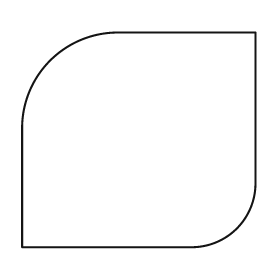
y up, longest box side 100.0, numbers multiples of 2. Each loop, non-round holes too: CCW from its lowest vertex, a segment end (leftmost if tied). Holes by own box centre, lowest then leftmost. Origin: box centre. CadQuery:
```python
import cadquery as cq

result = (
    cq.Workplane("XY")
    .moveTo(-50.0, -46.0)
    .lineTo(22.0, -46.0)
    .threePointArc((42.0, -38.0), (50.0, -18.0))
    .lineTo(50.0, 46.0)
    .lineTo(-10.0, 46.0)
    .threePointArc((-38.0, 34.0), (-50.0, 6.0))
    .close()
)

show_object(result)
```